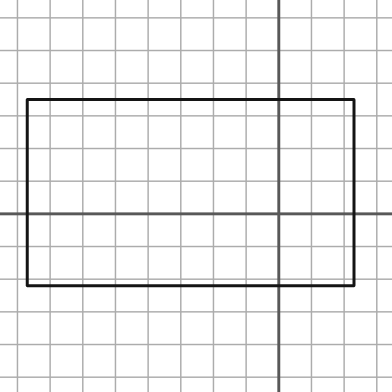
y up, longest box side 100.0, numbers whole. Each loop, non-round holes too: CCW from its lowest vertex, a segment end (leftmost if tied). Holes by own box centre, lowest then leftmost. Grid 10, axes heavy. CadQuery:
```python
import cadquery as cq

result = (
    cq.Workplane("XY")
    .moveTo(-77.0, -22.0)
    .lineTo(23.0, -22.0)
    .lineTo(23.0, 35.0)
    .lineTo(-77.0, 35.0)
    .close()
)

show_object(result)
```